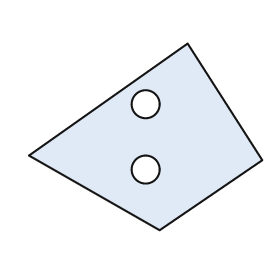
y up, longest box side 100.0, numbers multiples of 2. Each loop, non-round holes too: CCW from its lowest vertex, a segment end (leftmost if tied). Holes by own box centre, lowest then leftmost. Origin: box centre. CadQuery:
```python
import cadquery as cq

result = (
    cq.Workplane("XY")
    .moveTo(6.0, -40.0)
    .lineTo(50.0, -10.0)
    .lineTo(18.0, 40.0)
    .lineTo(-50.0, -8.0)
    .close()
    .moveTo(0.0, -14.0)
    .circle(6.0)
    .moveTo(0.0, 14.0)
    .circle(6.0)
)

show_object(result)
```